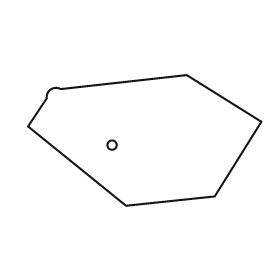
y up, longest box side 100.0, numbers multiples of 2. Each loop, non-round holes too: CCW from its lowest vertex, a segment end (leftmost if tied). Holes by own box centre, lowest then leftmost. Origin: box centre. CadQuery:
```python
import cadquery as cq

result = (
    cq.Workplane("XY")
    .moveTo(-8.0, -28.0)
    .lineTo(30.0, -24.0)
    .lineTo(50.0, 8.0)
    .lineTo(18.0, 28.0)
    .lineTo(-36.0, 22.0)
    .threePointArc((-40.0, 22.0), (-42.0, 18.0))
    .lineTo(-50.0, 6.0)
    .close()
    .moveTo(-14.0, -2.0)
    .circle(2.0)
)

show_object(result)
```